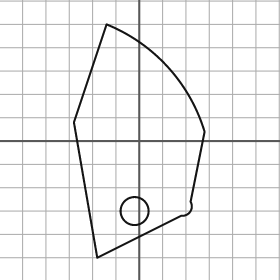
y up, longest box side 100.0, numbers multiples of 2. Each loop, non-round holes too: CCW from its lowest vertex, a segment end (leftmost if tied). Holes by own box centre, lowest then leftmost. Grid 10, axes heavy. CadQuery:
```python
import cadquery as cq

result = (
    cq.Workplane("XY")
    .moveTo(-18.0, -50.0)
    .lineTo(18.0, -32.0)
    .threePointArc((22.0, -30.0), (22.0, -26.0))
    .lineTo(28.0, 4.0)
    .threePointArc((12.0, 32.0), (-14.0, 50.0))
    .lineTo(-28.0, 8.0)
    .close()
    .moveTo(-2.0, -30.0)
    .circle(6.0)
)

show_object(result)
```